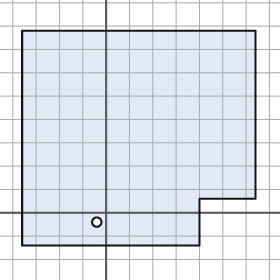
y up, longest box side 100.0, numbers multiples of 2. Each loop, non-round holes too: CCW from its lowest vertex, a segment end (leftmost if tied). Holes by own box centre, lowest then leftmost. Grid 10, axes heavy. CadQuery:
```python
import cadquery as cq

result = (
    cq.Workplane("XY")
    .moveTo(-36.0, -14.0)
    .lineTo(40.0, -14.0)
    .lineTo(40.0, 6.0)
    .lineTo(64.0, 6.0)
    .lineTo(64.0, 78.0)
    .lineTo(-36.0, 78.0)
    .close()
    .moveTo(-4.0, -4.0)
    .circle(2.0)
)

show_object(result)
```